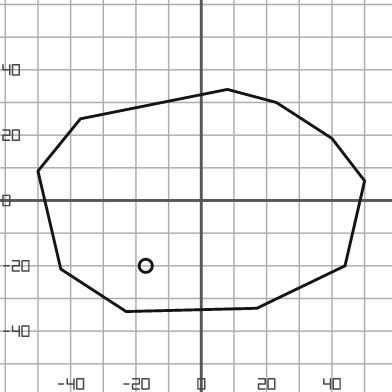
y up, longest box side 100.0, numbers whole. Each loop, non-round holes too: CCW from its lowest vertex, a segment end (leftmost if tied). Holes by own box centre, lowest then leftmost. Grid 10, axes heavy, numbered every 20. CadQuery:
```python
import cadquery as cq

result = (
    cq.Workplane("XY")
    .moveTo(-23.0, -34.0)
    .lineTo(17.0, -33.0)
    .lineTo(44.0, -20.0)
    .lineTo(50.0, 6.0)
    .lineTo(40.0, 19.0)
    .lineTo(23.0, 30.0)
    .lineTo(8.0, 34.0)
    .lineTo(-37.0, 25.0)
    .lineTo(-50.0, 9.0)
    .lineTo(-43.0, -21.0)
    .close()
    .moveTo(-17.0, -20.0)
    .circle(2.0)
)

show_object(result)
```